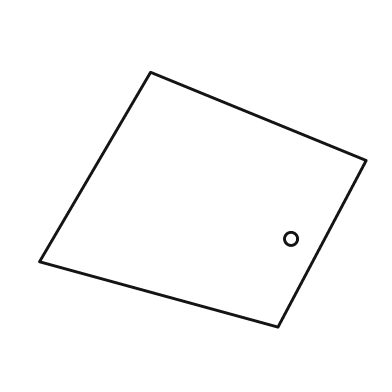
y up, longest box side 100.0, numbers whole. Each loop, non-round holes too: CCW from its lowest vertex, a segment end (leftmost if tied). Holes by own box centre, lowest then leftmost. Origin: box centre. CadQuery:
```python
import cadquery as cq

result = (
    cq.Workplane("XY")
    .moveTo(23.0, -39.0)
    .lineTo(50.0, 12.0)
    .lineTo(-16.0, 39.0)
    .lineTo(-50.0, -19.0)
    .close()
    .moveTo(27.0, -12.0)
    .circle(2.0)
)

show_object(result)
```